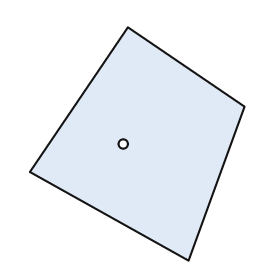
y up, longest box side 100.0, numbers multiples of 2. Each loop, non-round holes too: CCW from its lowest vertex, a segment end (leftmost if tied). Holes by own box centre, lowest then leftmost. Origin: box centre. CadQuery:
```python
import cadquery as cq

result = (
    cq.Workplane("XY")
    .moveTo(22.0, -50.0)
    .lineTo(46.0, 16.0)
    .lineTo(-4.0, 50.0)
    .lineTo(-46.0, -12.0)
    .close()
    .moveTo(-6.0, 0.0)
    .circle(2.0)
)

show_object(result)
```